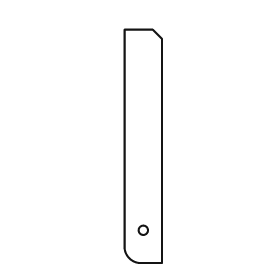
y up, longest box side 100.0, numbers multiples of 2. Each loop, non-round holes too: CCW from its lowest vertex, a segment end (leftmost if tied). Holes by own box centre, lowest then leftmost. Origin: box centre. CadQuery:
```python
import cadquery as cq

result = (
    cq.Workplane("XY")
    .moveTo(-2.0, -50.0)
    .lineTo(8.0, -50.0)
    .lineTo(8.0, 46.0)
    .lineTo(4.0, 50.0)
    .lineTo(-8.0, 50.0)
    .lineTo(-8.0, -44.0)
    .threePointArc((-6.0, -48.0), (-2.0, -50.0))
    .close()
    .moveTo(0.0, -36.0)
    .circle(2.0)
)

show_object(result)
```